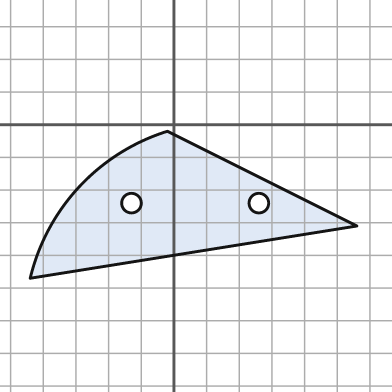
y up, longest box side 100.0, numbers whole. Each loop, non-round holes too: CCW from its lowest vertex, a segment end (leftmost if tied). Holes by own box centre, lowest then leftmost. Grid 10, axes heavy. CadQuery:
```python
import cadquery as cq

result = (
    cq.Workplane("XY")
    .moveTo(-44.0, -47.0)
    .lineTo(56.0, -31.0)
    .lineTo(-2.0, -2.0)
    .threePointArc((-29.0, -19.0), (-44.0, -47.0))
    .close()
    .moveTo(-13.0, -24.0)
    .circle(3.0)
    .moveTo(26.0, -24.0)
    .circle(3.0)
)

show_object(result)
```